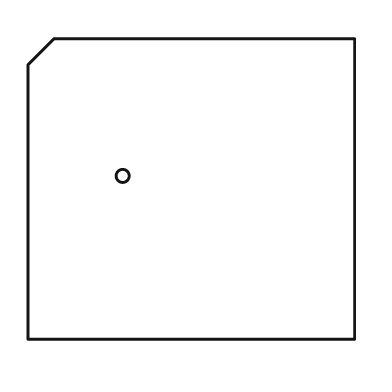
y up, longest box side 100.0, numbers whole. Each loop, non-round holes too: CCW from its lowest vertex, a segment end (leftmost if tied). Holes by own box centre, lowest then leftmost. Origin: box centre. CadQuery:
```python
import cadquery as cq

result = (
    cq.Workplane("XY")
    .moveTo(-50.0, -46.0)
    .lineTo(50.0, -46.0)
    .lineTo(50.0, 46.0)
    .lineTo(-42.0, 46.0)
    .lineTo(-50.0, 38.0)
    .close()
    .moveTo(-21.0, 4.0)
    .circle(2.0)
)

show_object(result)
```